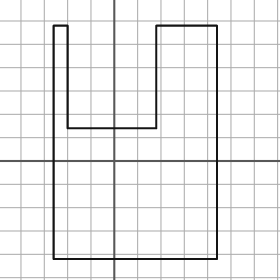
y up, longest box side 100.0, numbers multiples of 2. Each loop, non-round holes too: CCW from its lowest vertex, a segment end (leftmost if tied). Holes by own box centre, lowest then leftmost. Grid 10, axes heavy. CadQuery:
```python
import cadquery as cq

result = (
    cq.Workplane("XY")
    .moveTo(-26.0, -42.0)
    .lineTo(44.0, -42.0)
    .lineTo(44.0, 58.0)
    .lineTo(18.0, 58.0)
    .lineTo(18.0, 14.0)
    .lineTo(-20.0, 14.0)
    .lineTo(-20.0, 58.0)
    .lineTo(-26.0, 58.0)
    .close()
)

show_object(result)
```